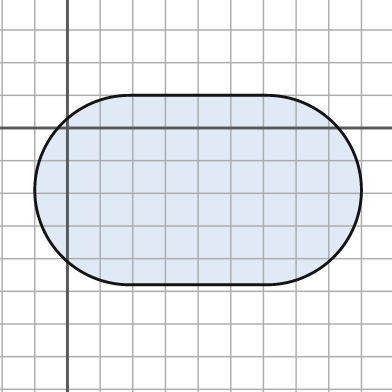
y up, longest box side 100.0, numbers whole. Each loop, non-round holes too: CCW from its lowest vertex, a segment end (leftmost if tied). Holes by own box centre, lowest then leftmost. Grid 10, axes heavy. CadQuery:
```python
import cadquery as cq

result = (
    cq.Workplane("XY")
    .moveTo(19.0, -48.0)
    .lineTo(61.0, -48.0)
    .threePointArc((90.0, -19.0), (61.0, 10.0))
    .lineTo(19.0, 10.0)
    .threePointArc((-10.0, -19.0), (19.0, -48.0))
    .close()
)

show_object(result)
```